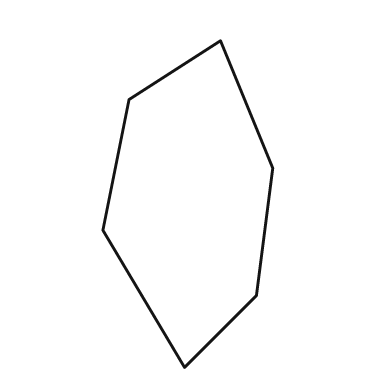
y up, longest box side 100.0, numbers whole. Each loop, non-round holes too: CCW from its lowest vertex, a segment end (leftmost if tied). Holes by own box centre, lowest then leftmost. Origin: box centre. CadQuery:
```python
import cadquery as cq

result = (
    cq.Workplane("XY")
    .moveTo(-1.0, -50.0)
    .lineTo(21.0, -28.0)
    .lineTo(26.0, 11.0)
    .lineTo(10.0, 50.0)
    .lineTo(-18.0, 32.0)
    .lineTo(-26.0, -8.0)
    .close()
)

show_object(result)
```